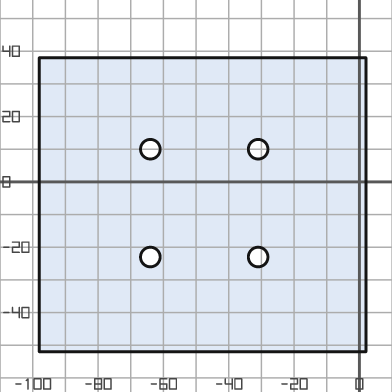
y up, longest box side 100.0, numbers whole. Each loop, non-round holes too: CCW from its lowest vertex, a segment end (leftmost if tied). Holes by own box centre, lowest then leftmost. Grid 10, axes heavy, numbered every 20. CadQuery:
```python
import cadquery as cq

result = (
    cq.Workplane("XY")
    .moveTo(-98.0, -52.0)
    .lineTo(2.0, -52.0)
    .lineTo(2.0, 38.0)
    .lineTo(-98.0, 38.0)
    .close()
    .moveTo(-64.0, -23.0)
    .circle(3.0)
    .moveTo(-31.0, -23.0)
    .circle(3.0)
    .moveTo(-64.0, 10.0)
    .circle(3.0)
    .moveTo(-31.0, 10.0)
    .circle(3.0)
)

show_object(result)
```